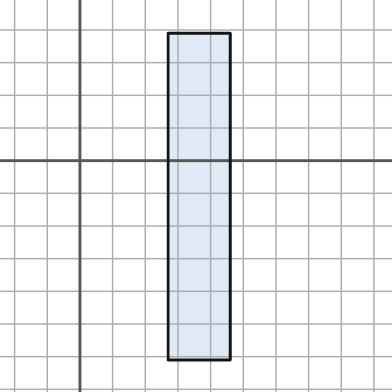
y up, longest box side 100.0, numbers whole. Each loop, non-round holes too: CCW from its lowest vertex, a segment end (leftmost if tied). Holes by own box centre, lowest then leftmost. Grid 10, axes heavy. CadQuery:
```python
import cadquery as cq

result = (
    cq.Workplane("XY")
    .moveTo(27.0, -61.0)
    .lineTo(46.0, -61.0)
    .lineTo(46.0, 39.0)
    .lineTo(27.0, 39.0)
    .close()
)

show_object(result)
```